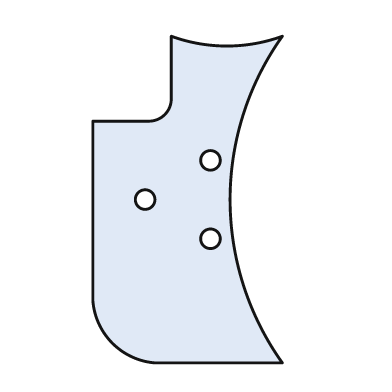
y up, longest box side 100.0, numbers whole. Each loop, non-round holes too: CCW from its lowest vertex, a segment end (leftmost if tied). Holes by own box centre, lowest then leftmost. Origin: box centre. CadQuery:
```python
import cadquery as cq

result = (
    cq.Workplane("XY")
    .moveTo(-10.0, -50.0)
    .lineTo(29.0, -50.0)
    .threePointArc((13.0, 0.0), (29.0, 50.0))
    .threePointArc((12.0, 47.0), (-5.0, 50.0))
    .lineTo(-5.0, 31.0)
    .threePointArc((-7.0, 26.0), (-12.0, 24.0))
    .lineTo(-29.0, 24.0)
    .lineTo(-29.0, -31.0)
    .threePointArc((-23.0, -44.0), (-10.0, -50.0))
    .close()
    .moveTo(7.0, -12.0)
    .circle(3.0)
    .moveTo(-13.0, 0.0)
    .circle(3.0)
    .moveTo(7.0, 12.0)
    .circle(3.0)
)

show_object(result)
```